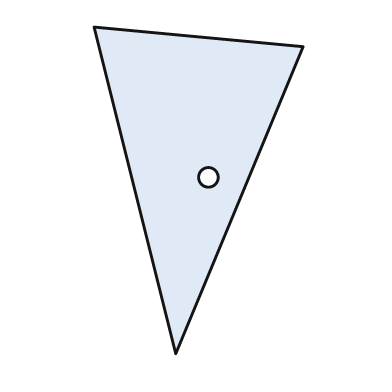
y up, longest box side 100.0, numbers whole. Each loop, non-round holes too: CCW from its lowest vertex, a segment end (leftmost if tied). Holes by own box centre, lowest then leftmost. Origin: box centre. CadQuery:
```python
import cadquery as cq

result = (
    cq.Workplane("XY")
    .moveTo(-7.0, -50.0)
    .lineTo(32.0, 44.0)
    .lineTo(-32.0, 50.0)
    .close()
    .moveTo(3.0, 4.0)
    .circle(3.0)
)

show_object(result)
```